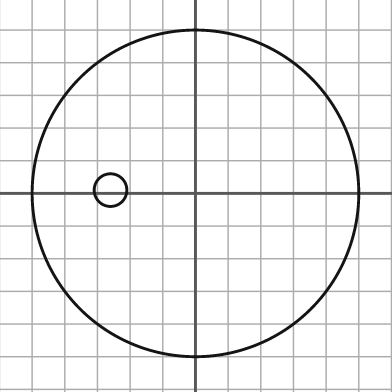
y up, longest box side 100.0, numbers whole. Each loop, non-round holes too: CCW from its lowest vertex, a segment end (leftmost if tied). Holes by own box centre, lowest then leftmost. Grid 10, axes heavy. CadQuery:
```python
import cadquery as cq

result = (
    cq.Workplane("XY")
    .moveTo(0.0, 0.0)
    .circle(50.0)
    .moveTo(-26.0, 1.0)
    .circle(5.0)
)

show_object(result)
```